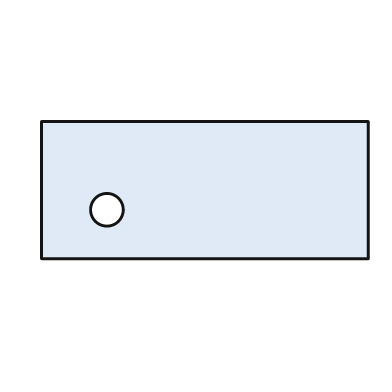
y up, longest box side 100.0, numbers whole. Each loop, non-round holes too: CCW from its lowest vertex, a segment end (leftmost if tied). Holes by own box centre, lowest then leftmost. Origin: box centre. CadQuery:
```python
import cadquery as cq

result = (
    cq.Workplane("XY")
    .moveTo(-50.0, -21.0)
    .lineTo(50.0, -21.0)
    .lineTo(50.0, 21.0)
    .lineTo(-50.0, 21.0)
    .close()
    .moveTo(-30.0, -6.0)
    .circle(5.0)
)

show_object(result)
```